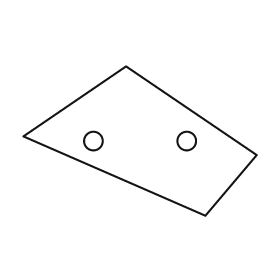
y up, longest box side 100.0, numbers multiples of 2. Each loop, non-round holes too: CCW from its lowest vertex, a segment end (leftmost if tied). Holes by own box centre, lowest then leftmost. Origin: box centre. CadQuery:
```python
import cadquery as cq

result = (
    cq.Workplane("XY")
    .moveTo(28.0, -32.0)
    .lineTo(50.0, -6.0)
    .lineTo(-6.0, 32.0)
    .lineTo(-50.0, 2.0)
    .close()
    .moveTo(-20.0, 0.0)
    .circle(4.0)
    .moveTo(20.0, 0.0)
    .circle(4.0)
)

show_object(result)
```